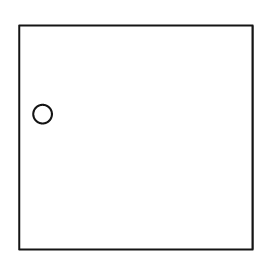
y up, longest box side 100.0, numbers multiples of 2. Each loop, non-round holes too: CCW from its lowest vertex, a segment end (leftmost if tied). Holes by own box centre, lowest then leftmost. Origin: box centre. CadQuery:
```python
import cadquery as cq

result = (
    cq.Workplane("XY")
    .moveTo(-50.0, -48.0)
    .lineTo(50.0, -48.0)
    .lineTo(50.0, 48.0)
    .lineTo(-50.0, 48.0)
    .close()
    .moveTo(-40.0, 10.0)
    .circle(4.0)
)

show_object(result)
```